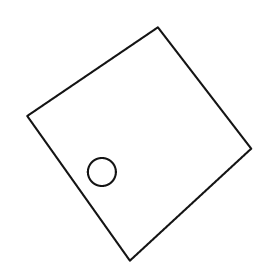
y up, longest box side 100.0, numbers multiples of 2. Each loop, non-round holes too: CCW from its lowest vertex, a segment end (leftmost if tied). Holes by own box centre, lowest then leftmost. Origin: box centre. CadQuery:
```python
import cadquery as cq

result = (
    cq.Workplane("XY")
    .moveTo(-4.0, -50.0)
    .lineTo(48.0, -2.0)
    .lineTo(8.0, 50.0)
    .lineTo(-48.0, 12.0)
    .close()
    .moveTo(-16.0, -12.0)
    .circle(6.0)
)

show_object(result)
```